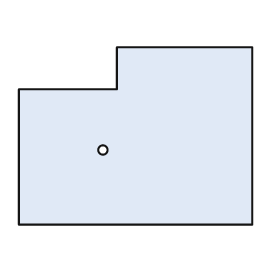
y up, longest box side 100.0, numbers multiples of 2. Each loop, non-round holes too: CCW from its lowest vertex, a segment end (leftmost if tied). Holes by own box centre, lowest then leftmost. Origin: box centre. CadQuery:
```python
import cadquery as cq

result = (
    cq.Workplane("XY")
    .moveTo(-50.0, -38.0)
    .lineTo(50.0, -38.0)
    .lineTo(50.0, 38.0)
    .lineTo(-8.0, 38.0)
    .lineTo(-8.0, 20.0)
    .lineTo(-50.0, 20.0)
    .close()
    .moveTo(-14.0, -6.0)
    .circle(2.0)
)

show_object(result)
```